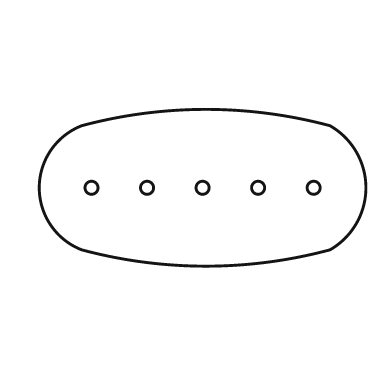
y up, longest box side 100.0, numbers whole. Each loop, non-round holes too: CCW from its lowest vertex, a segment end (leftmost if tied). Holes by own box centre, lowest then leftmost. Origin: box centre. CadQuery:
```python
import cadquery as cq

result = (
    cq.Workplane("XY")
    .moveTo(-37.0, -19.0)
    .threePointArc((1.0, -24.0), (39.0, -19.0))
    .threePointArc((50.0, 0.0), (39.0, 19.0))
    .threePointArc((1.0, 24.0), (-37.0, 19.0))
    .threePointArc((-50.0, 0.0), (-37.0, -19.0))
    .close()
    .moveTo(-34.0, 0.0)
    .circle(2.0)
    .moveTo(-17.0, 0.0)
    .circle(2.0)
    .moveTo(0.0, 0.0)
    .circle(2.0)
    .moveTo(17.0, 0.0)
    .circle(2.0)
    .moveTo(34.0, 0.0)
    .circle(2.0)
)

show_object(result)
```